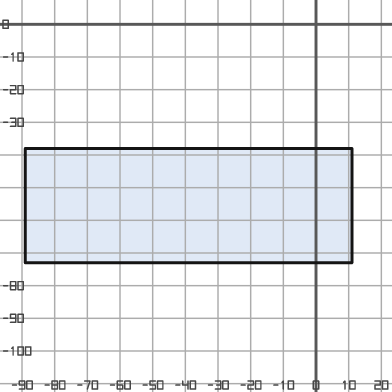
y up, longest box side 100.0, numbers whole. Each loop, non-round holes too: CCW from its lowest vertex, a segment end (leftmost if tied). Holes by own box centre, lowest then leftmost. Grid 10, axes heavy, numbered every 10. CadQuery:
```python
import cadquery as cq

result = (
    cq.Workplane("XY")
    .moveTo(-89.0, -73.0)
    .lineTo(11.0, -73.0)
    .lineTo(11.0, -38.0)
    .lineTo(-89.0, -38.0)
    .close()
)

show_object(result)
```